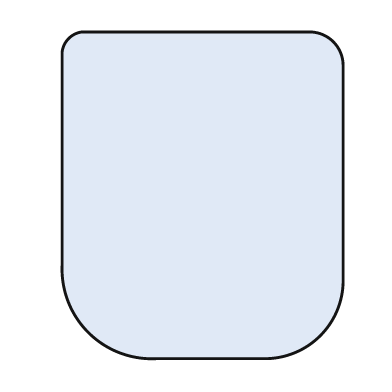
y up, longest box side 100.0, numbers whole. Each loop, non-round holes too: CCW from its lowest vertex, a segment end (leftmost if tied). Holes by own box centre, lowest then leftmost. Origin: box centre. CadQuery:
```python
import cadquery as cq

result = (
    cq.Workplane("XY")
    .moveTo(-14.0, -50.0)
    .lineTo(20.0, -50.0)
    .threePointArc((36.0, -43.0), (43.0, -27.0))
    .lineTo(43.0, 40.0)
    .threePointArc((40.0, 47.0), (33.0, 50.0))
    .lineTo(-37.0, 50.0)
    .threePointArc((-41.0, 48.0), (-43.0, 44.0))
    .lineTo(-43.0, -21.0)
    .threePointArc((-35.0, -42.0), (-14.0, -50.0))
    .close()
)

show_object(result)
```